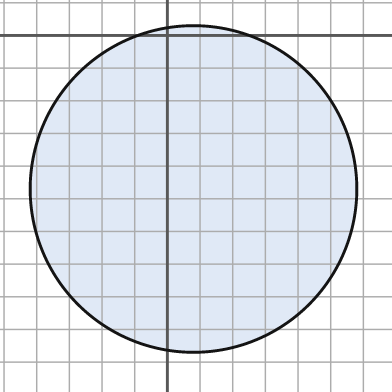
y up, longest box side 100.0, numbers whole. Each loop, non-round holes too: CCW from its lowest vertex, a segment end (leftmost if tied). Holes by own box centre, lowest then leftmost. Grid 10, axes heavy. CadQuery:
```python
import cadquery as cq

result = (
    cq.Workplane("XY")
    .moveTo(8.0, -47.0)
    .circle(50.0)
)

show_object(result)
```